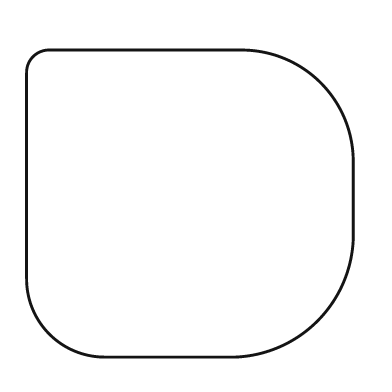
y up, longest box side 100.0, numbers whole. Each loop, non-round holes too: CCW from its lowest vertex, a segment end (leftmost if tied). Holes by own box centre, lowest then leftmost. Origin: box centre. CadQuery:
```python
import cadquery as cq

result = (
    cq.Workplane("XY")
    .moveTo(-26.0, -47.0)
    .lineTo(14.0, -47.0)
    .threePointArc((39.0, -36.0), (50.0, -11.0))
    .lineTo(50.0, 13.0)
    .threePointArc((40.0, 37.0), (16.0, 47.0))
    .lineTo(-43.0, 47.0)
    .threePointArc((-48.0, 45.0), (-50.0, 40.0))
    .lineTo(-50.0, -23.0)
    .threePointArc((-43.0, -40.0), (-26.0, -47.0))
    .close()
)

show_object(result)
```